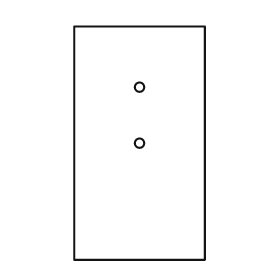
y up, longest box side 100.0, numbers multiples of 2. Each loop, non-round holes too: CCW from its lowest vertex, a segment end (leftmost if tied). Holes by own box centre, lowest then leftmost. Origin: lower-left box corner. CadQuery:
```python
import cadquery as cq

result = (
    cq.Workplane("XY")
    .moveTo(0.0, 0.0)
    .lineTo(56.0, 0.0)
    .lineTo(56.0, 100.0)
    .lineTo(0.0, 100.0)
    .close()
    .moveTo(28.0, 50.0)
    .circle(2.0)
    .moveTo(28.0, 74.0)
    .circle(2.0)
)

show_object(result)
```